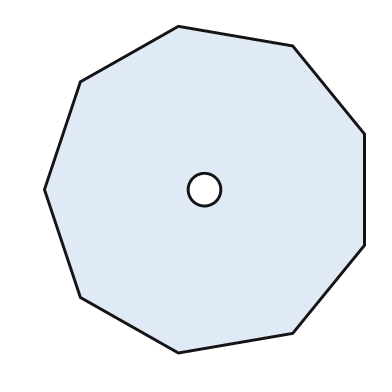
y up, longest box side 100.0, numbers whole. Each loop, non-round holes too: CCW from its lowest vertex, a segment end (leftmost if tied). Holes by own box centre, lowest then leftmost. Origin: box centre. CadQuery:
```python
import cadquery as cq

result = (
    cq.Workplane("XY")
    .moveTo(-8.0, -50.0)
    .lineTo(27.0, -44.0)
    .lineTo(49.0, -17.0)
    .lineTo(49.0, 17.0)
    .lineTo(27.0, 44.0)
    .lineTo(-8.0, 50.0)
    .lineTo(-38.0, 33.0)
    .lineTo(-49.0, 0.0)
    .lineTo(-38.0, -33.0)
    .close()
    .moveTo(0.0, 0.0)
    .circle(5.0)
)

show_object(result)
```